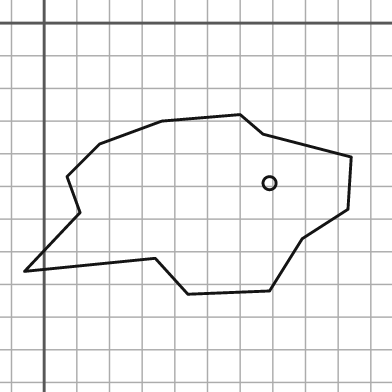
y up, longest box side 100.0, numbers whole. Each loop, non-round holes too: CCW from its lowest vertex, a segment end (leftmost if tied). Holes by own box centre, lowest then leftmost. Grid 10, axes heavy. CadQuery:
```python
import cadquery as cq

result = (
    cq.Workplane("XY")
    .moveTo(44.0, -83.0)
    .lineTo(69.0, -82.0)
    .lineTo(79.0, -66.0)
    .lineTo(93.0, -57.0)
    .lineTo(94.0, -41.0)
    .lineTo(67.0, -34.0)
    .lineTo(60.0, -28.0)
    .lineTo(36.0, -30.0)
    .lineTo(17.0, -37.0)
    .lineTo(7.0, -47.0)
    .lineTo(11.0, -58.0)
    .lineTo(-6.0, -76.0)
    .lineTo(34.0, -72.0)
    .close()
    .moveTo(69.0, -49.0)
    .circle(2.0)
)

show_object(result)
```